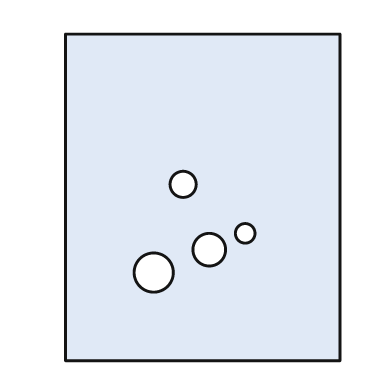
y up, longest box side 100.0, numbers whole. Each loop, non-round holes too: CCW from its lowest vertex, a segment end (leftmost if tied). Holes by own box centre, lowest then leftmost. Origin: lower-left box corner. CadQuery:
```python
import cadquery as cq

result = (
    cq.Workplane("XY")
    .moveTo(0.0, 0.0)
    .lineTo(84.0, 0.0)
    .lineTo(84.0, 100.0)
    .lineTo(0.0, 100.0)
    .close()
    .moveTo(27.0, 27.0)
    .circle(6.0)
    .moveTo(44.0, 34.0)
    .circle(5.0)
    .moveTo(55.0, 39.0)
    .circle(3.0)
    .moveTo(36.0, 54.0)
    .circle(4.0)
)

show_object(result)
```